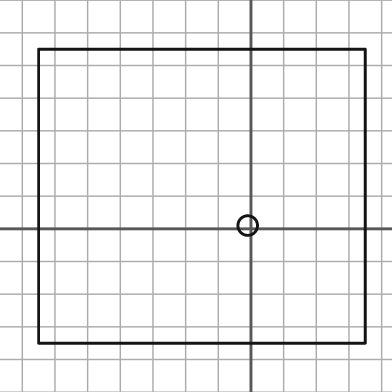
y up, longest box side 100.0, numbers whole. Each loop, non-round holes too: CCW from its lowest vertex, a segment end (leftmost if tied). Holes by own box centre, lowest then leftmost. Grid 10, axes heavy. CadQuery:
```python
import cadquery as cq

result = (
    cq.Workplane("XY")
    .moveTo(-65.0, -35.0)
    .lineTo(35.0, -35.0)
    .lineTo(35.0, 55.0)
    .lineTo(-65.0, 55.0)
    .close()
    .moveTo(-1.0, 1.0)
    .circle(3.0)
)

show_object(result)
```